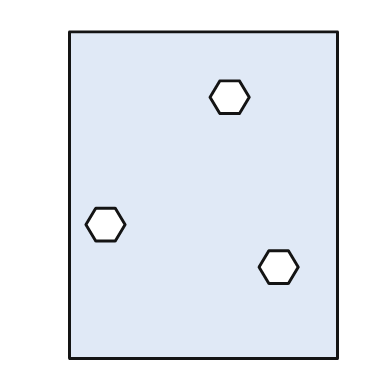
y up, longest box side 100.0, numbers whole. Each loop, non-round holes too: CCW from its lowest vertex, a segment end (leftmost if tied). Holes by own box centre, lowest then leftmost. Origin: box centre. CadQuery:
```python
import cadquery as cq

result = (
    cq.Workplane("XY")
    .moveTo(-41.0, -50.0)
    .lineTo(41.0, -50.0)
    .lineTo(41.0, 50.0)
    .lineTo(-41.0, 50.0)
    .close()
    .moveTo(20.0, -27.0)
    .lineTo(26.0, -27.0)
    .lineTo(29.0, -22.0)
    .lineTo(26.0, -17.0)
    .lineTo(20.0, -17.0)
    .lineTo(17.0, -22.0)
    .close()
    .moveTo(-33.0, -14.0)
    .lineTo(-27.0, -14.0)
    .lineTo(-24.0, -9.0)
    .lineTo(-27.0, -4.0)
    .lineTo(-33.0, -4.0)
    .lineTo(-36.0, -9.0)
    .close()
    .moveTo(5.0, 25.0)
    .lineTo(11.0, 25.0)
    .lineTo(14.0, 30.0)
    .lineTo(11.0, 35.0)
    .lineTo(5.0, 35.0)
    .lineTo(2.0, 30.0)
    .close()
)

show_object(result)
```